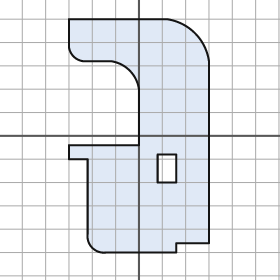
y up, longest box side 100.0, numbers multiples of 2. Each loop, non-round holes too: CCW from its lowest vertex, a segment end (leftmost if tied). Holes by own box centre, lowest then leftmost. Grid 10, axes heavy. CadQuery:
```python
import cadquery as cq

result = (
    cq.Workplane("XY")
    .moveTo(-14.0, -50.0)
    .lineTo(16.0, -50.0)
    .lineTo(16.0, -46.0)
    .lineTo(30.0, -46.0)
    .lineTo(30.0, 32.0)
    .threePointArc((24.0, 44.0), (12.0, 50.0))
    .lineTo(-30.0, 50.0)
    .lineTo(-30.0, 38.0)
    .threePointArc((-28.0, 34.0), (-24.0, 32.0))
    .lineTo(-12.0, 32.0)
    .threePointArc((-4.0, 28.0), (0.0, 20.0))
    .lineTo(0.0, -4.0)
    .lineTo(-30.0, -4.0)
    .lineTo(-30.0, -10.0)
    .lineTo(-22.0, -10.0)
    .lineTo(-22.0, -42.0)
    .threePointArc((-20.0, -48.0), (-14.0, -50.0))
    .close()
    .moveTo(8.0, -20.0)
    .lineTo(16.0, -20.0)
    .lineTo(16.0, -8.0)
    .lineTo(8.0, -8.0)
    .close()
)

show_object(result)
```